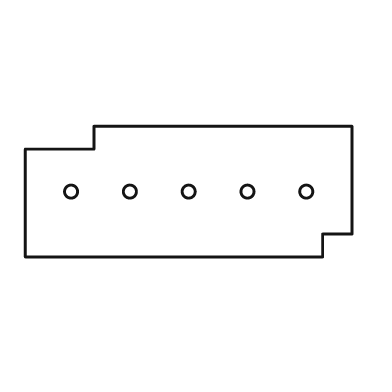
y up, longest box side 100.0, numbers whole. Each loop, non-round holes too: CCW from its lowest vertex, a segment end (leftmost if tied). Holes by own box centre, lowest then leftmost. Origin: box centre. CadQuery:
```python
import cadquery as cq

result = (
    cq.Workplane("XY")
    .moveTo(-50.0, -20.0)
    .lineTo(41.0, -20.0)
    .lineTo(41.0, -13.0)
    .lineTo(50.0, -13.0)
    .lineTo(50.0, 20.0)
    .lineTo(-29.0, 20.0)
    .lineTo(-29.0, 13.0)
    .lineTo(-50.0, 13.0)
    .close()
    .moveTo(-36.0, 0.0)
    .circle(2.0)
    .moveTo(-18.0, 0.0)
    .circle(2.0)
    .moveTo(0.0, 0.0)
    .circle(2.0)
    .moveTo(18.0, 0.0)
    .circle(2.0)
    .moveTo(36.0, 0.0)
    .circle(2.0)
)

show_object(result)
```